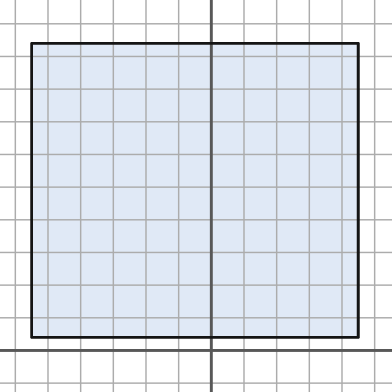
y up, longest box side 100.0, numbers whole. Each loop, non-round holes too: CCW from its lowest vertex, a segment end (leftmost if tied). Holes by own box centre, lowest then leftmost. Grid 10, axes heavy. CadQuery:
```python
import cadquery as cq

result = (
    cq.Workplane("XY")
    .moveTo(-55.0, 4.0)
    .lineTo(45.0, 4.0)
    .lineTo(45.0, 94.0)
    .lineTo(-55.0, 94.0)
    .close()
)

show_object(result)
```